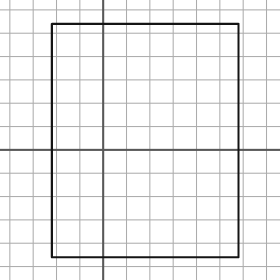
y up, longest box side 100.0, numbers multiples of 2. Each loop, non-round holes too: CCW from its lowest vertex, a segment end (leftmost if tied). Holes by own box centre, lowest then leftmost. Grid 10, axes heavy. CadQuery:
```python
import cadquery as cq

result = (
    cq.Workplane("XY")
    .moveTo(-22.0, -46.0)
    .lineTo(58.0, -46.0)
    .lineTo(58.0, 54.0)
    .lineTo(-22.0, 54.0)
    .close()
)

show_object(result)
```